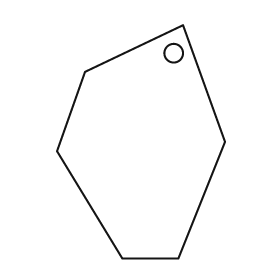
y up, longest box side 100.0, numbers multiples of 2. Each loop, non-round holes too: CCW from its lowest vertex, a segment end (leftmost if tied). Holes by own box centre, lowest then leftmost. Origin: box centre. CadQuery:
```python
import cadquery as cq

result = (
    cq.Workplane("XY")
    .moveTo(-8.0, -50.0)
    .lineTo(16.0, -50.0)
    .lineTo(36.0, 0.0)
    .lineTo(18.0, 50.0)
    .lineTo(-24.0, 30.0)
    .lineTo(-36.0, -4.0)
    .close()
    .moveTo(14.0, 38.0)
    .circle(4.0)
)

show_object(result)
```